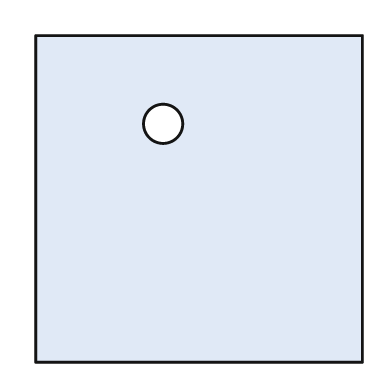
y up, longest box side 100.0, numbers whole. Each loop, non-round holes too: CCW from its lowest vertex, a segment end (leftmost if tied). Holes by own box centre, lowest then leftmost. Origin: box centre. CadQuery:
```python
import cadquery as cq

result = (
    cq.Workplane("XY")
    .moveTo(-50.0, -50.0)
    .lineTo(50.0, -50.0)
    .lineTo(50.0, 50.0)
    .lineTo(-50.0, 50.0)
    .close()
    .moveTo(-11.0, 23.0)
    .circle(6.0)
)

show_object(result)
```